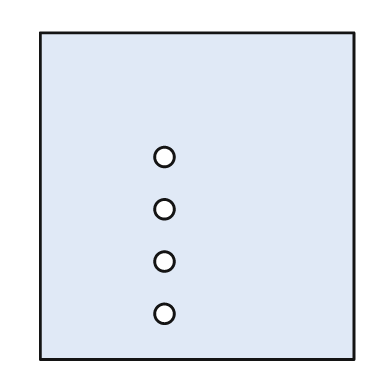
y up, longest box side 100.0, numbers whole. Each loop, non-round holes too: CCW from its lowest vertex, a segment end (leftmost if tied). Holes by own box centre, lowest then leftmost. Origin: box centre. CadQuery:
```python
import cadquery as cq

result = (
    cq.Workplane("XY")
    .moveTo(-48.0, -50.0)
    .lineTo(48.0, -50.0)
    .lineTo(48.0, 50.0)
    .lineTo(-48.0, 50.0)
    .close()
    .moveTo(-10.0, -36.0)
    .circle(3.0)
    .moveTo(-10.0, -20.0)
    .circle(3.0)
    .moveTo(-10.0, -4.0)
    .circle(3.0)
    .moveTo(-10.0, 12.0)
    .circle(3.0)
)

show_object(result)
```